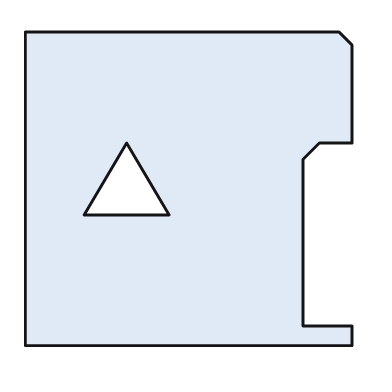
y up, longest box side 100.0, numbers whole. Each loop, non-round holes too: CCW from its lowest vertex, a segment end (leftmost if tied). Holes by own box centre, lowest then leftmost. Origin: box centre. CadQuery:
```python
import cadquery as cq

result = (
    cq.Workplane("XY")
    .moveTo(-50.0, -48.0)
    .lineTo(50.0, -48.0)
    .lineTo(50.0, -42.0)
    .lineTo(35.0, -42.0)
    .lineTo(35.0, 9.0)
    .lineTo(40.0, 14.0)
    .lineTo(50.0, 14.0)
    .lineTo(50.0, 44.0)
    .lineTo(46.0, 48.0)
    .lineTo(-50.0, 48.0)
    .close()
    .moveTo(-32.0, -8.0)
    .lineTo(-6.0, -8.0)
    .lineTo(-19.0, 14.0)
    .close()
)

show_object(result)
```